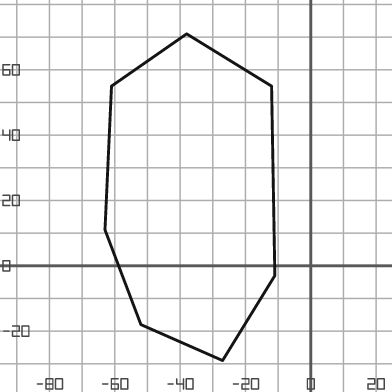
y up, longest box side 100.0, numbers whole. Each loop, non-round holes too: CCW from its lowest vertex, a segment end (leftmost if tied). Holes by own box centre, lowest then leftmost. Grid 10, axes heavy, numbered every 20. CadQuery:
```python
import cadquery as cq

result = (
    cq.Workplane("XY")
    .moveTo(-27.0, -29.0)
    .lineTo(-11.0, -3.0)
    .lineTo(-12.0, 55.0)
    .lineTo(-38.0, 71.0)
    .lineTo(-61.0, 55.0)
    .lineTo(-63.0, 11.0)
    .lineTo(-52.0, -18.0)
    .close()
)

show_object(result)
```